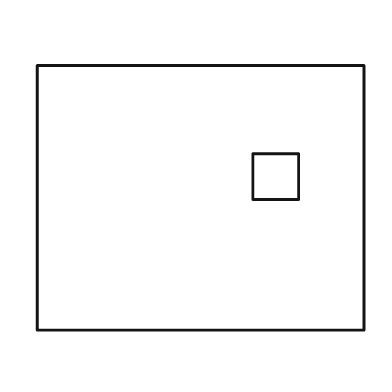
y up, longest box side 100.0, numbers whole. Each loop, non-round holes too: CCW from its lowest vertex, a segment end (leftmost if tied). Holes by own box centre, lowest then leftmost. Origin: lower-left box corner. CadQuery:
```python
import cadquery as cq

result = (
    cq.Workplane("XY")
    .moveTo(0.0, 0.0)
    .lineTo(100.0, 0.0)
    .lineTo(100.0, 81.0)
    .lineTo(0.0, 81.0)
    .close()
    .moveTo(66.0, 40.0)
    .lineTo(80.0, 40.0)
    .lineTo(80.0, 54.0)
    .lineTo(66.0, 54.0)
    .close()
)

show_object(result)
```